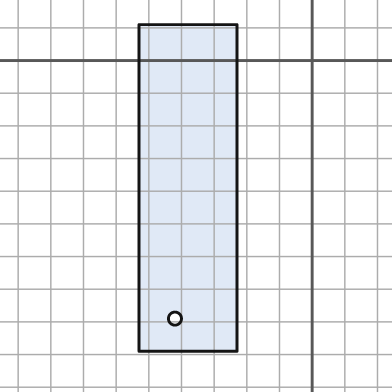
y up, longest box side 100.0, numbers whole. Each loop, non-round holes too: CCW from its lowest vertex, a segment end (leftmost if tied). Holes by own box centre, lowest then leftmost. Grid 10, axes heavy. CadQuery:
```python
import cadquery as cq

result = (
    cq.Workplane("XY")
    .moveTo(-53.0, -89.0)
    .lineTo(-23.0, -89.0)
    .lineTo(-23.0, 11.0)
    .lineTo(-53.0, 11.0)
    .close()
    .moveTo(-42.0, -79.0)
    .circle(2.0)
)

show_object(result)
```